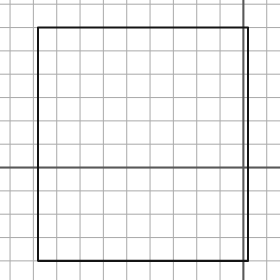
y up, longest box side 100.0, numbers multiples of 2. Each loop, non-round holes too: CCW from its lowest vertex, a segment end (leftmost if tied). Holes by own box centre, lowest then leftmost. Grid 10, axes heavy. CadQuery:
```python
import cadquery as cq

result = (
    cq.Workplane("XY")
    .moveTo(-88.0, -40.0)
    .lineTo(2.0, -40.0)
    .lineTo(2.0, 60.0)
    .lineTo(-88.0, 60.0)
    .close()
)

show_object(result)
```